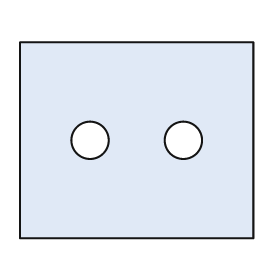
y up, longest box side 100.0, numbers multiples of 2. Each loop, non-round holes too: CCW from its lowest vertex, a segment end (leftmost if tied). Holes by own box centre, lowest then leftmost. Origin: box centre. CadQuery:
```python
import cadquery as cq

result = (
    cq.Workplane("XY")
    .moveTo(-50.0, -42.0)
    .lineTo(50.0, -42.0)
    .lineTo(50.0, 42.0)
    .lineTo(-50.0, 42.0)
    .close()
    .moveTo(-20.0, 0.0)
    .circle(8.0)
    .moveTo(20.0, 0.0)
    .circle(8.0)
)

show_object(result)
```